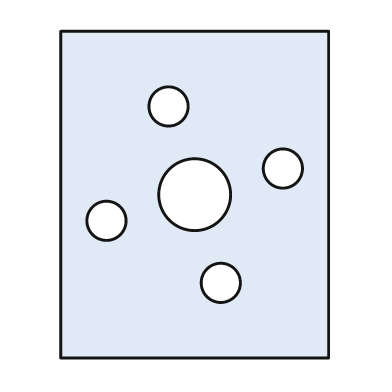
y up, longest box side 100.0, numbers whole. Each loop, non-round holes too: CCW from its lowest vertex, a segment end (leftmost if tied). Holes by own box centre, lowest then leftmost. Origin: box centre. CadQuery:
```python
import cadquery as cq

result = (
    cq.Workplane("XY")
    .moveTo(-41.0, -50.0)
    .lineTo(41.0, -50.0)
    .lineTo(41.0, 50.0)
    .lineTo(-41.0, 50.0)
    .close()
    .moveTo(8.0, -27.0)
    .circle(6.0)
    .moveTo(-27.0, -8.0)
    .circle(6.0)
    .moveTo(0.0, 0.0)
    .circle(11.0)
    .moveTo(27.0, 8.0)
    .circle(6.0)
    .moveTo(-8.0, 27.0)
    .circle(6.0)
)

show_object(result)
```